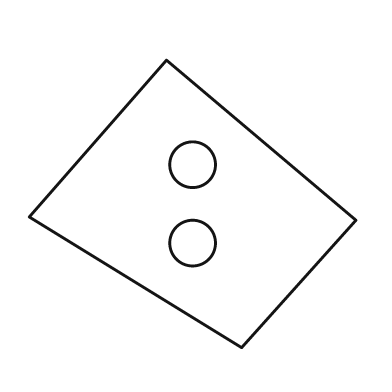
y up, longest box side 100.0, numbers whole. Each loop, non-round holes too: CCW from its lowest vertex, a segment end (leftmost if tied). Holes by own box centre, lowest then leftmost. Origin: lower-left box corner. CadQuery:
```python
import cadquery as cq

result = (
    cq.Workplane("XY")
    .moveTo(65.0, 0.0)
    .lineTo(100.0, 39.0)
    .lineTo(42.0, 88.0)
    .lineTo(0.0, 40.0)
    .close()
    .moveTo(50.0, 32.0)
    .circle(7.0)
    .moveTo(50.0, 56.0)
    .circle(7.0)
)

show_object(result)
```